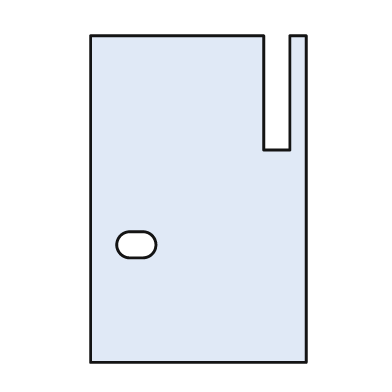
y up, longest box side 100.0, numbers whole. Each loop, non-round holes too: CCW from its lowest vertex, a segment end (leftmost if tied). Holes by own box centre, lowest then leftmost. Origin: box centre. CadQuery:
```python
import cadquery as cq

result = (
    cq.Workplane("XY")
    .moveTo(-33.0, -50.0)
    .lineTo(33.0, -50.0)
    .lineTo(33.0, 50.0)
    .lineTo(28.0, 50.0)
    .lineTo(28.0, 15.0)
    .lineTo(20.0, 15.0)
    .lineTo(20.0, 50.0)
    .lineTo(-33.0, 50.0)
    .close()
    .moveTo(-21.0, -18.0)
    .lineTo(-17.0, -18.0)
    .threePointArc((-13.0, -14.0), (-17.0, -10.0))
    .lineTo(-21.0, -10.0)
    .threePointArc((-25.0, -14.0), (-21.0, -18.0))
    .close()
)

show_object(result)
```